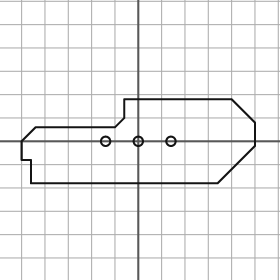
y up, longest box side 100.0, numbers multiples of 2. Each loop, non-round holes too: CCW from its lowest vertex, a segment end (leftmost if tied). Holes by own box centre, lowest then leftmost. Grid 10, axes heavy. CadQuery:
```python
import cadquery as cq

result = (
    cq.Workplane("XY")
    .moveTo(-46.0, -18.0)
    .lineTo(34.0, -18.0)
    .lineTo(50.0, -2.0)
    .lineTo(50.0, 8.0)
    .lineTo(40.0, 18.0)
    .lineTo(-6.0, 18.0)
    .lineTo(-6.0, 10.0)
    .lineTo(-10.0, 6.0)
    .lineTo(-44.0, 6.0)
    .lineTo(-50.0, 0.0)
    .lineTo(-50.0, -8.0)
    .lineTo(-46.0, -8.0)
    .close()
    .moveTo(-14.0, 0.0)
    .circle(2.0)
    .moveTo(0.0, 0.0)
    .circle(2.0)
    .moveTo(14.0, 0.0)
    .circle(2.0)
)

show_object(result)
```